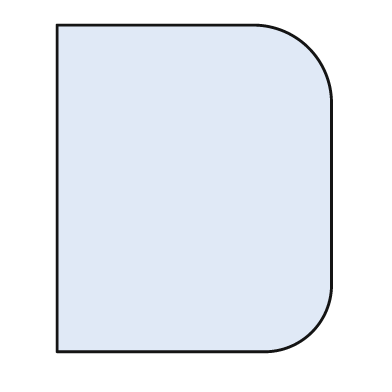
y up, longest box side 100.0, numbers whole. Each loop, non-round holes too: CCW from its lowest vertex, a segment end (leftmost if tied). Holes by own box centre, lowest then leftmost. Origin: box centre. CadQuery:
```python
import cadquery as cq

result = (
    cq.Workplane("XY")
    .moveTo(-42.0, -50.0)
    .lineTo(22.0, -50.0)
    .threePointArc((36.0, -44.0), (42.0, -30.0))
    .lineTo(42.0, 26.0)
    .threePointArc((35.0, 43.0), (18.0, 50.0))
    .lineTo(-42.0, 50.0)
    .close()
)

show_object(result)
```